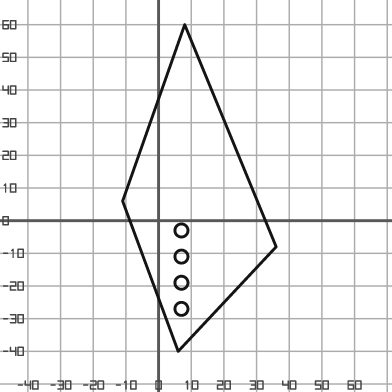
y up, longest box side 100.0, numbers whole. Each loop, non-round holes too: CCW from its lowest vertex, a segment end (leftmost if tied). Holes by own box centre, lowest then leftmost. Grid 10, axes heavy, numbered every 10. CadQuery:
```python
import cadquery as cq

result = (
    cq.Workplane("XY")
    .moveTo(6.0, -40.0)
    .lineTo(36.0, -8.0)
    .lineTo(8.0, 60.0)
    .lineTo(-11.0, 6.0)
    .close()
    .moveTo(7.0, -27.0)
    .circle(2.0)
    .moveTo(7.0, -19.0)
    .circle(2.0)
    .moveTo(7.0, -11.0)
    .circle(2.0)
    .moveTo(7.0, -3.0)
    .circle(2.0)
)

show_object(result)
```